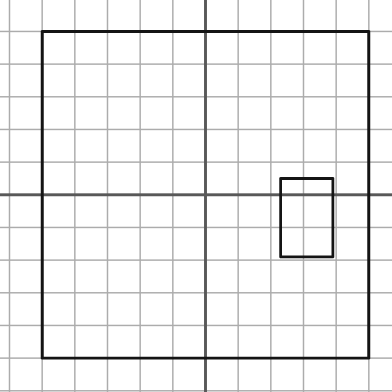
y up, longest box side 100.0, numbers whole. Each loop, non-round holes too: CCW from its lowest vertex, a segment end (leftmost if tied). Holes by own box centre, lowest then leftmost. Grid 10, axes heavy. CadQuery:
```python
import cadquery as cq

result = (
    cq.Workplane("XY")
    .moveTo(-50.0, -50.0)
    .lineTo(50.0, -50.0)
    .lineTo(50.0, 50.0)
    .lineTo(-50.0, 50.0)
    .close()
    .moveTo(23.0, -19.0)
    .lineTo(39.0, -19.0)
    .lineTo(39.0, 5.0)
    .lineTo(23.0, 5.0)
    .close()
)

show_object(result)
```